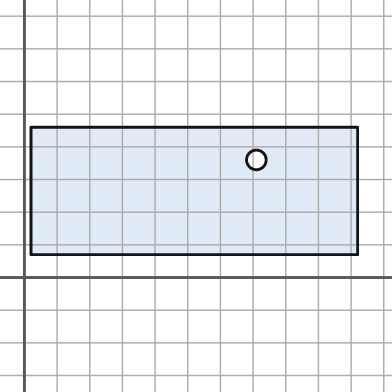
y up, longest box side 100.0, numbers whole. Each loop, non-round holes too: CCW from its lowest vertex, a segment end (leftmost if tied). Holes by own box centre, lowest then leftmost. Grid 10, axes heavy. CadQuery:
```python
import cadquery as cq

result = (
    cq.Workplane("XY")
    .moveTo(2.0, 7.0)
    .lineTo(102.0, 7.0)
    .lineTo(102.0, 46.0)
    .lineTo(2.0, 46.0)
    .close()
    .moveTo(71.0, 36.0)
    .circle(3.0)
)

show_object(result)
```